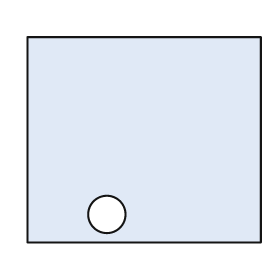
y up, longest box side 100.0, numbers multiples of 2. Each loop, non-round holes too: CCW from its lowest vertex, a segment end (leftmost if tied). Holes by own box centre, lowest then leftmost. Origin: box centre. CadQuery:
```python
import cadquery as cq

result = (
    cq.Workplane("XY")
    .moveTo(-50.0, -44.0)
    .lineTo(50.0, -44.0)
    .lineTo(50.0, 44.0)
    .lineTo(-50.0, 44.0)
    .close()
    .moveTo(-16.0, -32.0)
    .circle(8.0)
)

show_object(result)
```